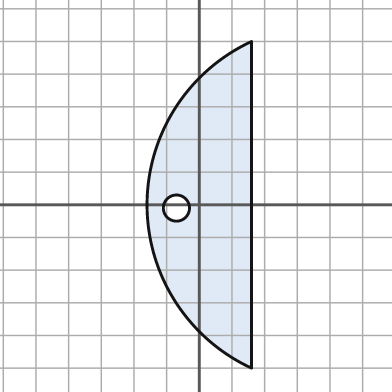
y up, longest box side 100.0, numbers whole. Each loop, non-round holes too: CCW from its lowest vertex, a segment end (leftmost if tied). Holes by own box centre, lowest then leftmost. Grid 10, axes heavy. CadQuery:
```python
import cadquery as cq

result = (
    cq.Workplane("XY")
    .moveTo(16.0, -50.0)
    .lineTo(16.0, 50.0)
    .threePointArc((-16.0, 0.0), (16.0, -50.0))
    .close()
    .moveTo(-7.0, -1.0)
    .circle(4.0)
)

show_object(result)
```